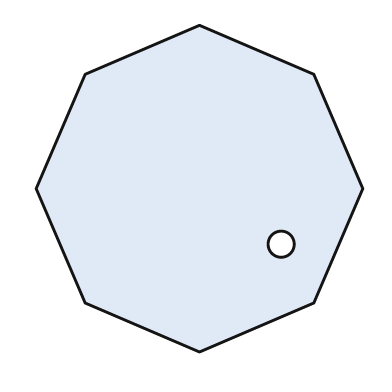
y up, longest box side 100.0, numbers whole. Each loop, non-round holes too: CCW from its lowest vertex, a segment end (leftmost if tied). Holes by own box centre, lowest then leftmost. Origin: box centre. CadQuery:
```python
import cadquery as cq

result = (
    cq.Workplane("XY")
    .moveTo(0.0, -50.0)
    .lineTo(35.0, -35.0)
    .lineTo(50.0, 0.0)
    .lineTo(35.0, 35.0)
    .lineTo(0.0, 50.0)
    .lineTo(-35.0, 35.0)
    .lineTo(-50.0, 0.0)
    .lineTo(-35.0, -35.0)
    .close()
    .moveTo(25.0, -17.0)
    .circle(4.0)
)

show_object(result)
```